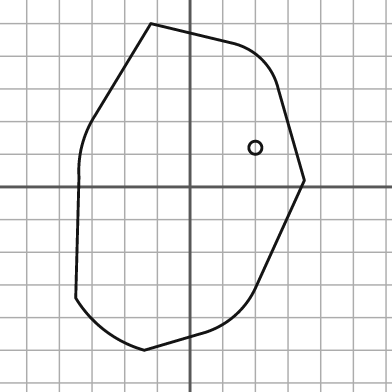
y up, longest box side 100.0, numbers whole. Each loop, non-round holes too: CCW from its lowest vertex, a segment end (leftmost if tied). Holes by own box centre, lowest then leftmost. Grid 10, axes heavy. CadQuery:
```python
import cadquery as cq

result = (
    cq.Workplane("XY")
    .moveTo(-14.0, -50.0)
    .lineTo(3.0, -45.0)
    .threePointArc((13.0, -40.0), (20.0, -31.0))
    .lineTo(35.0, 2.0)
    .lineTo(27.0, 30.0)
    .threePointArc((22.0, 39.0), (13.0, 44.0))
    .lineTo(-12.0, 50.0)
    .lineTo(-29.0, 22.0)
    .threePointArc((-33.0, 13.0), (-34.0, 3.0))
    .lineTo(-35.0, -34.0)
    .threePointArc((-26.0, -44.0), (-14.0, -50.0))
    .close()
    .moveTo(20.0, 12.0)
    .circle(2.0)
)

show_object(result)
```